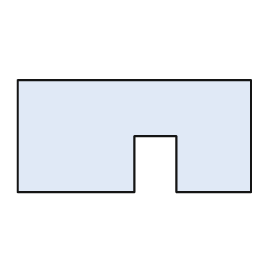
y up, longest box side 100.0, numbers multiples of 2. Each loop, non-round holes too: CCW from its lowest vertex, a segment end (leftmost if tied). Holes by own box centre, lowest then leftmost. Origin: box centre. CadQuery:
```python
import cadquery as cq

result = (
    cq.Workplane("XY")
    .moveTo(-50.0, -24.0)
    .lineTo(0.0, -24.0)
    .lineTo(0.0, 0.0)
    .lineTo(18.0, 0.0)
    .lineTo(18.0, -24.0)
    .lineTo(50.0, -24.0)
    .lineTo(50.0, 24.0)
    .lineTo(-50.0, 24.0)
    .close()
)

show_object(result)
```